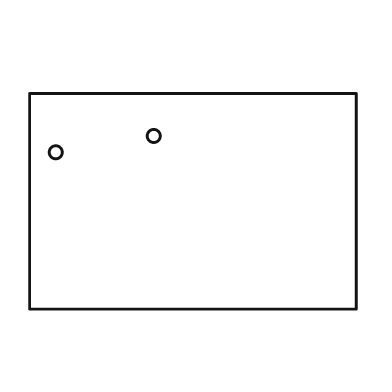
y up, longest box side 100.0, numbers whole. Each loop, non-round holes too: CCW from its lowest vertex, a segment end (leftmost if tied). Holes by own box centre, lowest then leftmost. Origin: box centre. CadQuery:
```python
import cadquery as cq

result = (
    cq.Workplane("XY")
    .moveTo(-50.0, -33.0)
    .lineTo(50.0, -33.0)
    .lineTo(50.0, 33.0)
    .lineTo(-50.0, 33.0)
    .close()
    .moveTo(-42.0, 15.0)
    .circle(2.0)
    .moveTo(-12.0, 20.0)
    .circle(2.0)
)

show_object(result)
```